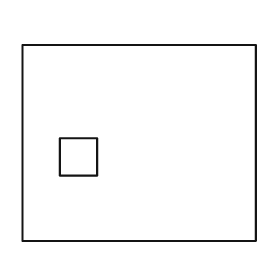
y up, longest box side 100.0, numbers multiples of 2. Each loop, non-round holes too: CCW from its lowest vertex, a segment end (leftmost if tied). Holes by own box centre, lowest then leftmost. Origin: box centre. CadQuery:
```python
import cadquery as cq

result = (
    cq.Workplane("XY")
    .moveTo(-50.0, -42.0)
    .lineTo(50.0, -42.0)
    .lineTo(50.0, 42.0)
    .lineTo(-50.0, 42.0)
    .close()
    .moveTo(-34.0, -14.0)
    .lineTo(-18.0, -14.0)
    .lineTo(-18.0, 2.0)
    .lineTo(-34.0, 2.0)
    .close()
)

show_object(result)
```